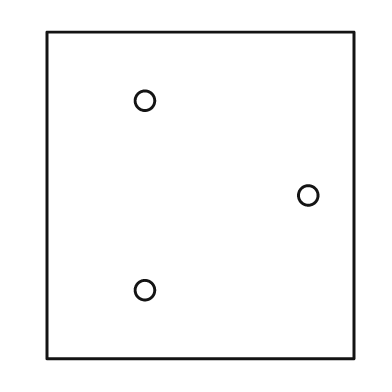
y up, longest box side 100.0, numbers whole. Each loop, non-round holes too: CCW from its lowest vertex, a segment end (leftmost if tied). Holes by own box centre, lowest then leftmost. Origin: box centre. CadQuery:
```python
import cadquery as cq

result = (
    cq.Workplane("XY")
    .moveTo(-47.0, -50.0)
    .lineTo(47.0, -50.0)
    .lineTo(47.0, 50.0)
    .lineTo(-47.0, 50.0)
    .close()
    .moveTo(-17.0, -29.0)
    .circle(3.0)
    .moveTo(33.0, 0.0)
    .circle(3.0)
    .moveTo(-17.0, 29.0)
    .circle(3.0)
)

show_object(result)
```